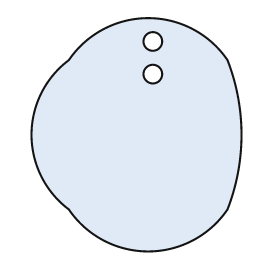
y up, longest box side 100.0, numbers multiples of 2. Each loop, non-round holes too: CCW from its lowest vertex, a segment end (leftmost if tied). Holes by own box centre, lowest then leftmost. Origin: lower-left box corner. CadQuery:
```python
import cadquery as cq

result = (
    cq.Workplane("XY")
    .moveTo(16.0, 18.0)
    .threePointArc((50.0, 0.0), (84.0, 18.0))
    .threePointArc((90.0, 50.0), (84.0, 82.0))
    .threePointArc((50.0, 100.0), (16.0, 82.0))
    .threePointArc((0.0, 50.0), (16.0, 18.0))
    .close()
    .moveTo(52.0, 76.0)
    .circle(4.0)
    .moveTo(52.0, 90.0)
    .circle(4.0)
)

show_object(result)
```